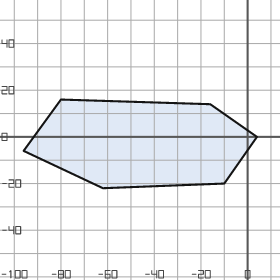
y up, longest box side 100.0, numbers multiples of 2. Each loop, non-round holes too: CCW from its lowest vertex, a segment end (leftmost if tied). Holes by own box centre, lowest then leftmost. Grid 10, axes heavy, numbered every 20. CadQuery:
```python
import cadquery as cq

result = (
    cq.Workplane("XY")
    .moveTo(-62.0, -22.0)
    .lineTo(-10.0, -20.0)
    .lineTo(4.0, 0.0)
    .lineTo(-16.0, 14.0)
    .lineTo(-80.0, 16.0)
    .lineTo(-96.0, -6.0)
    .close()
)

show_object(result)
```